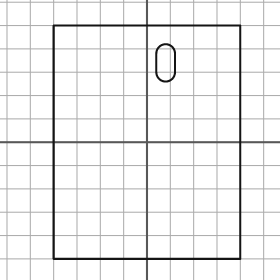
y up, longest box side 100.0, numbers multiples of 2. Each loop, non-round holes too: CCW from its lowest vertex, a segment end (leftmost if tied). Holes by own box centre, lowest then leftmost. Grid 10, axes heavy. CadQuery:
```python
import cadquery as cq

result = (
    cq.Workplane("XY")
    .moveTo(-40.0, -50.0)
    .lineTo(40.0, -50.0)
    .lineTo(40.0, 50.0)
    .lineTo(-40.0, 50.0)
    .close()
    .moveTo(4.0, 30.0)
    .threePointArc((8.0, 26.0), (12.0, 30.0))
    .lineTo(12.0, 38.0)
    .threePointArc((8.0, 42.0), (4.0, 38.0))
    .close()
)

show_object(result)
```